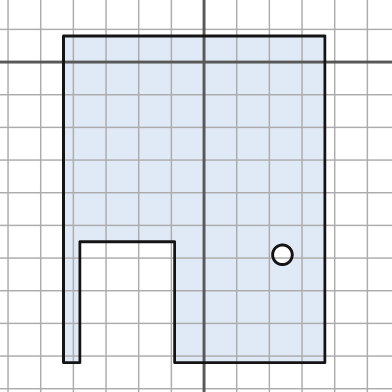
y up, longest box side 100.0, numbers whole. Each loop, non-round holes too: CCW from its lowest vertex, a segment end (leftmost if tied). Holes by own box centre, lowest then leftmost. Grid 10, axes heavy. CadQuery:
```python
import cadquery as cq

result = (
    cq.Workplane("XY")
    .moveTo(-43.0, -92.0)
    .lineTo(-38.0, -92.0)
    .lineTo(-38.0, -55.0)
    .lineTo(-9.0, -55.0)
    .lineTo(-9.0, -92.0)
    .lineTo(37.0, -92.0)
    .lineTo(37.0, 8.0)
    .lineTo(-43.0, 8.0)
    .close()
    .moveTo(24.0, -59.0)
    .circle(3.0)
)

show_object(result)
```